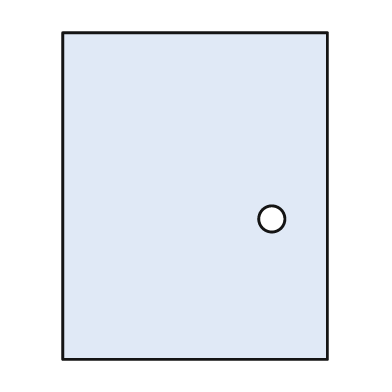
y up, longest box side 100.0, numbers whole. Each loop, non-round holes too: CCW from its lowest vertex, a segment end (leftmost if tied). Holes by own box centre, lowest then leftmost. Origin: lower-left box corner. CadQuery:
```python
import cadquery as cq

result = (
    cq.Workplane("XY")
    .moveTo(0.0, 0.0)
    .lineTo(81.0, 0.0)
    .lineTo(81.0, 100.0)
    .lineTo(0.0, 100.0)
    .close()
    .moveTo(64.0, 43.0)
    .circle(4.0)
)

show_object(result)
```